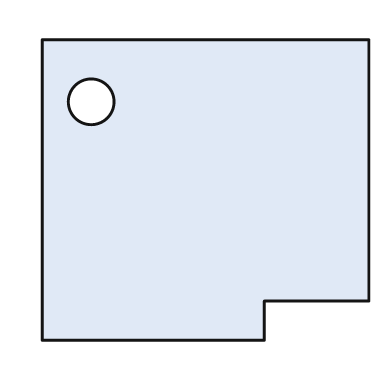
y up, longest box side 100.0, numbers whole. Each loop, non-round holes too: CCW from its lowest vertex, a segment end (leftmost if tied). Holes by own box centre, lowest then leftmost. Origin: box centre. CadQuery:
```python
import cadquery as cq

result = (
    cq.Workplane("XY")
    .moveTo(-50.0, -46.0)
    .lineTo(18.0, -46.0)
    .lineTo(18.0, -34.0)
    .lineTo(50.0, -34.0)
    .lineTo(50.0, 46.0)
    .lineTo(-50.0, 46.0)
    .close()
    .moveTo(-35.0, 27.0)
    .circle(7.0)
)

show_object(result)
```